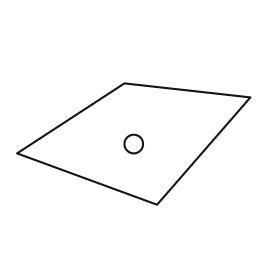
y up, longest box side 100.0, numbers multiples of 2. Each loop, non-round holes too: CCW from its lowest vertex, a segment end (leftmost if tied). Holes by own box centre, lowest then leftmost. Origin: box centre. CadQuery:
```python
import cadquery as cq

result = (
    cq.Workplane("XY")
    .moveTo(10.0, -26.0)
    .lineTo(50.0, 20.0)
    .lineTo(-4.0, 26.0)
    .lineTo(-50.0, -4.0)
    .close()
    .moveTo(0.0, 0.0)
    .circle(4.0)
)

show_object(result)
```